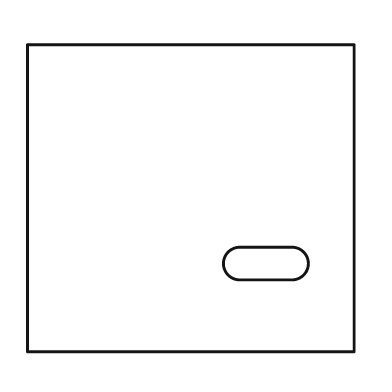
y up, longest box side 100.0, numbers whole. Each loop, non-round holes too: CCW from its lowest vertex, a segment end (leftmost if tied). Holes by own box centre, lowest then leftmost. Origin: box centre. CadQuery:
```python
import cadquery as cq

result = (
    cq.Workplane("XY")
    .moveTo(-50.0, -47.0)
    .lineTo(50.0, -47.0)
    .lineTo(50.0, 47.0)
    .lineTo(-50.0, 47.0)
    .close()
    .moveTo(15.0, -25.0)
    .lineTo(31.0, -25.0)
    .threePointArc((36.0, -20.0), (31.0, -15.0))
    .lineTo(15.0, -15.0)
    .threePointArc((10.0, -20.0), (15.0, -25.0))
    .close()
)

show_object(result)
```